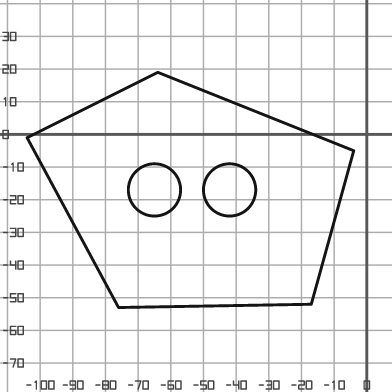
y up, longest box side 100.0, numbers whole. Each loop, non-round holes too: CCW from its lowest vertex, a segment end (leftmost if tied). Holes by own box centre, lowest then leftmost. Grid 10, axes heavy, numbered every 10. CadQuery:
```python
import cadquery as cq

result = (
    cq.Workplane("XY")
    .moveTo(-76.0, -53.0)
    .lineTo(-17.0, -52.0)
    .lineTo(-4.0, -5.0)
    .lineTo(-64.0, 19.0)
    .lineTo(-104.0, -1.0)
    .close()
    .moveTo(-65.0, -17.0)
    .circle(8.0)
    .moveTo(-42.0, -17.0)
    .circle(8.0)
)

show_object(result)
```